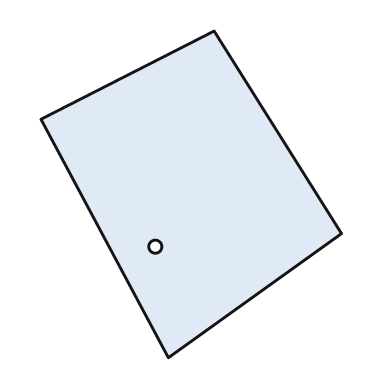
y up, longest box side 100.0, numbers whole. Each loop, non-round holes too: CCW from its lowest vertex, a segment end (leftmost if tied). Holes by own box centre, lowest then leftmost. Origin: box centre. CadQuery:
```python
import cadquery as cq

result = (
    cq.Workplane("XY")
    .moveTo(-7.0, -50.0)
    .lineTo(46.0, -12.0)
    .lineTo(7.0, 50.0)
    .lineTo(-46.0, 23.0)
    .close()
    .moveTo(-11.0, -16.0)
    .circle(2.0)
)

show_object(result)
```